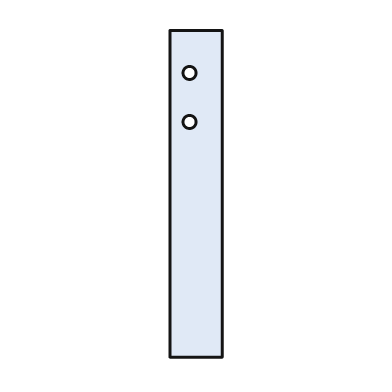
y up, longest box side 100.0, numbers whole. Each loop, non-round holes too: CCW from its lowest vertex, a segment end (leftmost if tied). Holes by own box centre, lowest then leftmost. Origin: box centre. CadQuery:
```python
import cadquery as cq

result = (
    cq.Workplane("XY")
    .moveTo(-8.0, -50.0)
    .lineTo(8.0, -50.0)
    .lineTo(8.0, 50.0)
    .lineTo(-8.0, 50.0)
    .close()
    .moveTo(-2.0, 22.0)
    .circle(2.0)
    .moveTo(-2.0, 37.0)
    .circle(2.0)
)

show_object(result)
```